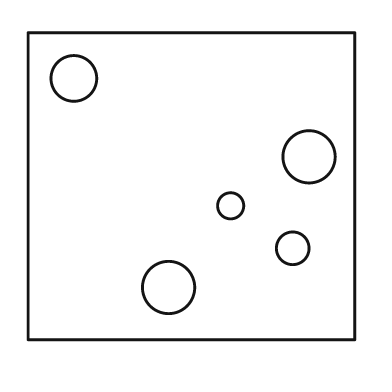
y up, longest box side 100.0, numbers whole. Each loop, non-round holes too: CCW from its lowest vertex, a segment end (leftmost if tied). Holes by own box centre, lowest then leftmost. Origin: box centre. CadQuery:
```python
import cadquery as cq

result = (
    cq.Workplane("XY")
    .moveTo(-50.0, -47.0)
    .lineTo(50.0, -47.0)
    .lineTo(50.0, 47.0)
    .lineTo(-50.0, 47.0)
    .close()
    .moveTo(-7.0, -31.0)
    .circle(8.0)
    .moveTo(31.0, -19.0)
    .circle(5.0)
    .moveTo(12.0, -6.0)
    .circle(4.0)
    .moveTo(36.0, 9.0)
    .circle(8.0)
    .moveTo(-36.0, 33.0)
    .circle(7.0)
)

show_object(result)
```